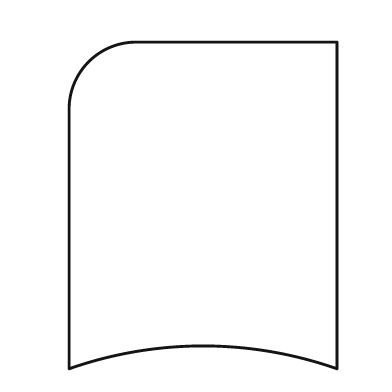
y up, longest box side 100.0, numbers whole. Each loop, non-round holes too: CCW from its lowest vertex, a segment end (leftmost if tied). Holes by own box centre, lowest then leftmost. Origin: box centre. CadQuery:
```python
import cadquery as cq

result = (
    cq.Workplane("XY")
    .moveTo(-41.0, -50.0)
    .threePointArc((0.0, -43.0), (41.0, -50.0))
    .lineTo(41.0, 50.0)
    .lineTo(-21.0, 50.0)
    .threePointArc((-35.0, 44.0), (-41.0, 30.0))
    .close()
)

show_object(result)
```